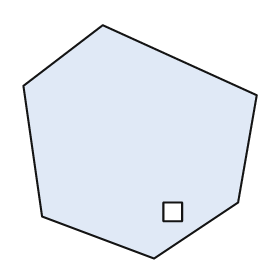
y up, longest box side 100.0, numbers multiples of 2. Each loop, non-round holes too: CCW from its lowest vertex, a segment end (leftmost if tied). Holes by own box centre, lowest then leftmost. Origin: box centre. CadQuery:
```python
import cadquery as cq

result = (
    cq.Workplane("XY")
    .moveTo(6.0, -50.0)
    .lineTo(42.0, -26.0)
    .lineTo(50.0, 20.0)
    .lineTo(-16.0, 50.0)
    .lineTo(-50.0, 24.0)
    .lineTo(-42.0, -32.0)
    .close()
    .moveTo(10.0, -34.0)
    .lineTo(18.0, -34.0)
    .lineTo(18.0, -26.0)
    .lineTo(10.0, -26.0)
    .close()
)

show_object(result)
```